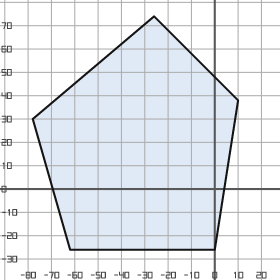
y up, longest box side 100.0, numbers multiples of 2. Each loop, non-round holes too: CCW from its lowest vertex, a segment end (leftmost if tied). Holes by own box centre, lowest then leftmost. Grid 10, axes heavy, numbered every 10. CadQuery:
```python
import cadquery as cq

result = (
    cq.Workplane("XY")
    .moveTo(-62.0, -26.0)
    .lineTo(0.0, -26.0)
    .lineTo(10.0, 38.0)
    .lineTo(-26.0, 74.0)
    .lineTo(-78.0, 30.0)
    .close()
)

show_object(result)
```